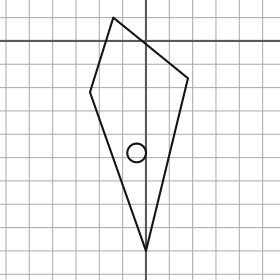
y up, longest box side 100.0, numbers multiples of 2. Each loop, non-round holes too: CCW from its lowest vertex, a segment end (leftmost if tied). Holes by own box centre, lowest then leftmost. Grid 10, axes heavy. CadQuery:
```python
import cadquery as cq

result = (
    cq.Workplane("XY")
    .moveTo(0.0, -90.0)
    .lineTo(18.0, -16.0)
    .lineTo(-14.0, 10.0)
    .lineTo(-24.0, -22.0)
    .close()
    .moveTo(-4.0, -48.0)
    .circle(4.0)
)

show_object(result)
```